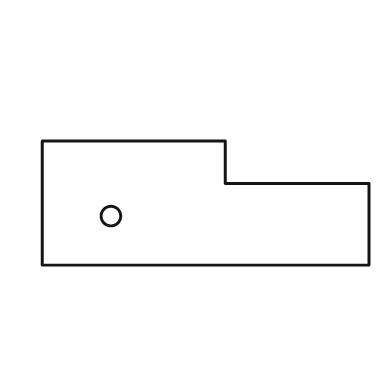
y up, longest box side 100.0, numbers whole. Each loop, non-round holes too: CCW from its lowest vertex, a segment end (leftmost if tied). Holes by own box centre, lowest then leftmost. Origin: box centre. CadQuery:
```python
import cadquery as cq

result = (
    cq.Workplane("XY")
    .moveTo(-50.0, -19.0)
    .lineTo(50.0, -19.0)
    .lineTo(50.0, 6.0)
    .lineTo(6.0, 6.0)
    .lineTo(6.0, 19.0)
    .lineTo(-50.0, 19.0)
    .close()
    .moveTo(-29.0, -4.0)
    .circle(3.0)
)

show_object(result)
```